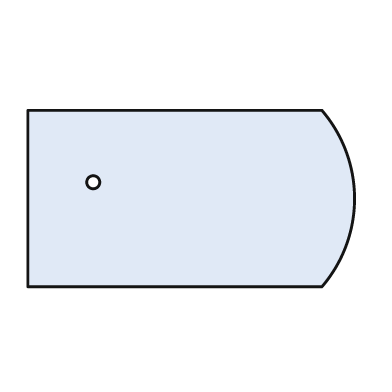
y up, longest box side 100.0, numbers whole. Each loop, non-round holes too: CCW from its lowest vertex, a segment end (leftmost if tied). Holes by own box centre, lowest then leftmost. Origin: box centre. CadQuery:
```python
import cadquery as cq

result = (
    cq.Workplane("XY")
    .moveTo(-50.0, -27.0)
    .lineTo(40.0, -27.0)
    .threePointArc((50.0, 0.0), (40.0, 27.0))
    .lineTo(-50.0, 27.0)
    .close()
    .moveTo(-30.0, 5.0)
    .circle(2.0)
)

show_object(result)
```